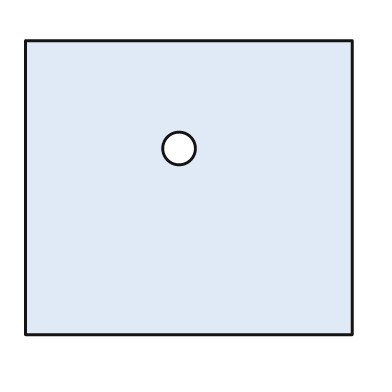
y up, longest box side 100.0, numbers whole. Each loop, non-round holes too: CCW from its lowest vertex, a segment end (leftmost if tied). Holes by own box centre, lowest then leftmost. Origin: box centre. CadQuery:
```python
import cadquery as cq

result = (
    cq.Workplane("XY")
    .moveTo(-50.0, -45.0)
    .lineTo(50.0, -45.0)
    .lineTo(50.0, 45.0)
    .lineTo(-50.0, 45.0)
    .close()
    .moveTo(-3.0, 12.0)
    .circle(5.0)
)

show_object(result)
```